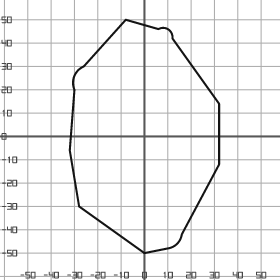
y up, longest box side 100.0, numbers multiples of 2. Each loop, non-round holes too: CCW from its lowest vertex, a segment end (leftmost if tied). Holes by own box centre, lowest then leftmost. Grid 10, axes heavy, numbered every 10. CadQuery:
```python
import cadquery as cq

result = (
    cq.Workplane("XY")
    .moveTo(0.0, -50.0)
    .lineTo(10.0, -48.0)
    .threePointArc((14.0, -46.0), (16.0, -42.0))
    .lineTo(32.0, -12.0)
    .lineTo(32.0, 14.0)
    .lineTo(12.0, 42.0)
    .threePointArc((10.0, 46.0), (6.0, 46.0))
    .lineTo(-8.0, 50.0)
    .lineTo(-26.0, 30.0)
    .threePointArc((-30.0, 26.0), (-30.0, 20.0))
    .lineTo(-32.0, -6.0)
    .lineTo(-28.0, -30.0)
    .close()
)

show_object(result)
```